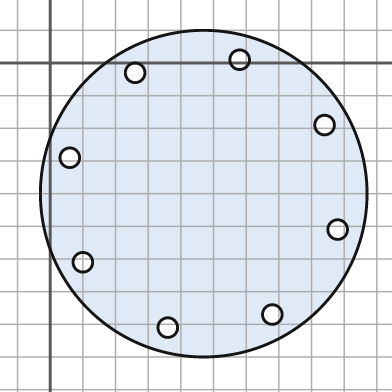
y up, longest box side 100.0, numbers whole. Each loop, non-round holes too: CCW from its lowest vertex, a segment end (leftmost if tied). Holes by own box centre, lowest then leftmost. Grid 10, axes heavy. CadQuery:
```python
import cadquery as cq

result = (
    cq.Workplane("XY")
    .moveTo(47.0, -40.0)
    .circle(50.0)
    .moveTo(36.0, -81.0)
    .circle(3.0)
    .moveTo(68.0, -77.0)
    .circle(3.0)
    .moveTo(10.0, -61.0)
    .circle(3.0)
    .moveTo(88.0, -51.0)
    .circle(3.0)
    .moveTo(6.0, -29.0)
    .circle(3.0)
    .moveTo(84.0, -19.0)
    .circle(3.0)
    .moveTo(26.0, -3.0)
    .circle(3.0)
    .moveTo(58.0, 1.0)
    .circle(3.0)
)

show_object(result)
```